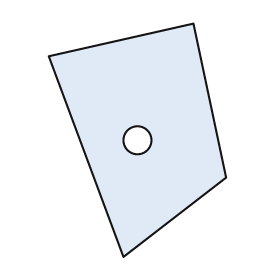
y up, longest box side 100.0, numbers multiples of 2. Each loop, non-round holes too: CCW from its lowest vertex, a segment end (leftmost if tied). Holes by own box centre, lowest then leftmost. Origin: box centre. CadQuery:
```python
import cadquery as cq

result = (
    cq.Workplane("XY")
    .moveTo(-6.0, -50.0)
    .lineTo(38.0, -16.0)
    .lineTo(24.0, 50.0)
    .lineTo(-38.0, 36.0)
    .close()
    .moveTo(0.0, 0.0)
    .circle(6.0)
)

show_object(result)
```